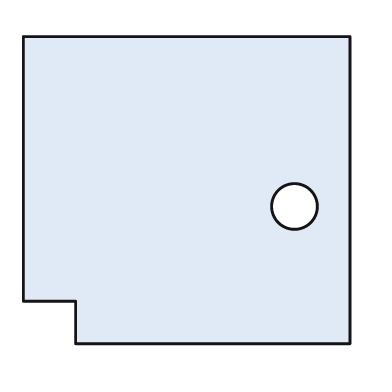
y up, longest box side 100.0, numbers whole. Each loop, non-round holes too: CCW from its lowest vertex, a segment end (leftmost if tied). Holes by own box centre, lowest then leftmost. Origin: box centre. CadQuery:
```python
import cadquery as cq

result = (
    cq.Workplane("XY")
    .moveTo(-34.0, -47.0)
    .lineTo(50.0, -47.0)
    .lineTo(50.0, 47.0)
    .lineTo(-50.0, 47.0)
    .lineTo(-50.0, -34.0)
    .lineTo(-34.0, -34.0)
    .close()
    .moveTo(33.0, -5.0)
    .circle(7.0)
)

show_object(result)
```